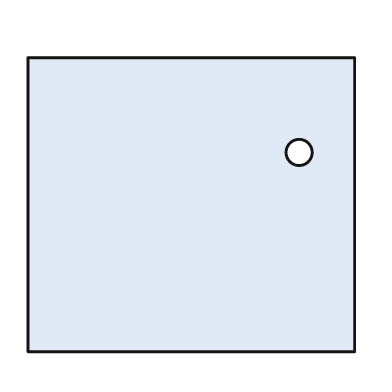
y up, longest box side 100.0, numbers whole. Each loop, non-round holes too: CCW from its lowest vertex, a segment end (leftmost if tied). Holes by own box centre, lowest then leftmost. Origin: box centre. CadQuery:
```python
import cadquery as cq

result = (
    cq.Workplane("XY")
    .moveTo(-50.0, -45.0)
    .lineTo(50.0, -45.0)
    .lineTo(50.0, 45.0)
    .lineTo(-50.0, 45.0)
    .close()
    .moveTo(33.0, 16.0)
    .circle(4.0)
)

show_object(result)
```